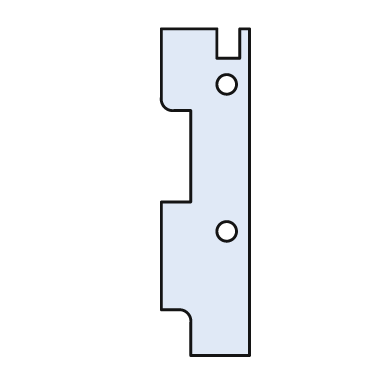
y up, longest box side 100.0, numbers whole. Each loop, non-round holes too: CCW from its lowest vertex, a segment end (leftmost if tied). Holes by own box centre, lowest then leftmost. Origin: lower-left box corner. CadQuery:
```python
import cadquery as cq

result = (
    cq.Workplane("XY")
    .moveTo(9.0, 0.0)
    .lineTo(27.0, 0.0)
    .lineTo(27.0, 100.0)
    .lineTo(24.0, 100.0)
    .lineTo(24.0, 91.0)
    .lineTo(17.0, 91.0)
    .lineTo(17.0, 100.0)
    .lineTo(0.0, 100.0)
    .lineTo(0.0, 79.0)
    .threePointArc((1.0, 76.0), (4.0, 75.0))
    .lineTo(9.0, 75.0)
    .lineTo(9.0, 47.0)
    .lineTo(0.0, 47.0)
    .lineTo(0.0, 14.0)
    .lineTo(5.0, 14.0)
    .threePointArc((8.0, 13.0), (9.0, 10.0))
    .close()
    .moveTo(20.0, 38.0)
    .circle(3.0)
    .moveTo(20.0, 83.0)
    .circle(3.0)
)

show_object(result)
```